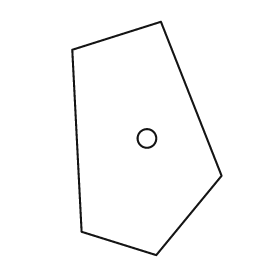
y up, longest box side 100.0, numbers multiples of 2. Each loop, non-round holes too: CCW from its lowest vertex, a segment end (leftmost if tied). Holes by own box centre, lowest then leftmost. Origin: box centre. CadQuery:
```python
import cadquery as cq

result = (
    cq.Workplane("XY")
    .moveTo(4.0, -50.0)
    .lineTo(32.0, -16.0)
    .lineTo(6.0, 50.0)
    .lineTo(-32.0, 38.0)
    .lineTo(-28.0, -40.0)
    .close()
    .moveTo(0.0, 0.0)
    .circle(4.0)
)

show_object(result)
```